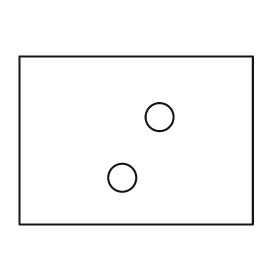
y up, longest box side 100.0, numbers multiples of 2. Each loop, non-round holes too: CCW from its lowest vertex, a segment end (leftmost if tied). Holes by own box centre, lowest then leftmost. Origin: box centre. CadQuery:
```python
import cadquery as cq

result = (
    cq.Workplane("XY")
    .moveTo(-50.0, -36.0)
    .lineTo(50.0, -36.0)
    .lineTo(50.0, 36.0)
    .lineTo(-50.0, 36.0)
    .close()
    .moveTo(-6.0, -16.0)
    .circle(6.0)
    .moveTo(10.0, 10.0)
    .circle(6.0)
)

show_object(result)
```